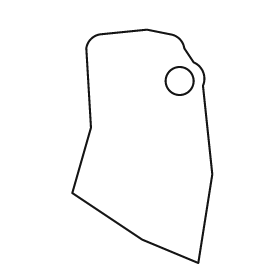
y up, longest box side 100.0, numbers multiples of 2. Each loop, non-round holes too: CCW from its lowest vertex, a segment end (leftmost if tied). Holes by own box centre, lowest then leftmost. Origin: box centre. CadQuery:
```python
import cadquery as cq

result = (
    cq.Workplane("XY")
    .moveTo(24.0, -50.0)
    .lineTo(30.0, -12.0)
    .lineTo(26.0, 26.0)
    .threePointArc((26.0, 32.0), (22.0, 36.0))
    .lineTo(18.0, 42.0)
    .threePointArc((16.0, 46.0), (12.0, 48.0))
    .lineTo(2.0, 50.0)
    .lineTo(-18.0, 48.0)
    .threePointArc((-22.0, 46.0), (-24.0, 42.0))
    .lineTo(-22.0, 8.0)
    .lineTo(-30.0, -20.0)
    .lineTo(0.0, -40.0)
    .close()
    .moveTo(16.0, 28.0)
    .circle(6.0)
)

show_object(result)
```